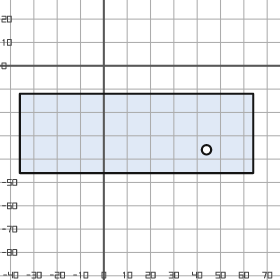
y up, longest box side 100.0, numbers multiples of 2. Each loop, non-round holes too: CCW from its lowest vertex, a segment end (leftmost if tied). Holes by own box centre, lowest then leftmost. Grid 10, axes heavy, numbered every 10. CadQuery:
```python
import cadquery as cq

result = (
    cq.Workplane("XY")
    .moveTo(-36.0, -46.0)
    .lineTo(64.0, -46.0)
    .lineTo(64.0, -12.0)
    .lineTo(-36.0, -12.0)
    .close()
    .moveTo(44.0, -36.0)
    .circle(2.0)
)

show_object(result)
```